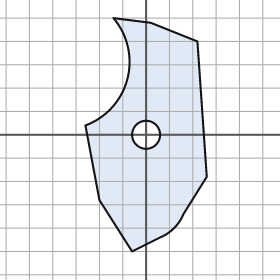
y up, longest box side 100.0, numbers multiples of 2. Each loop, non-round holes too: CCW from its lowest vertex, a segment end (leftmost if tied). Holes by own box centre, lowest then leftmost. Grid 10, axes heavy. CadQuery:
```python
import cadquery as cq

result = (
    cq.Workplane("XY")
    .moveTo(-6.0, -50.0)
    .lineTo(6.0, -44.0)
    .threePointArc((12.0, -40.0), (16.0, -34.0))
    .lineTo(26.0, -18.0)
    .lineTo(22.0, 40.0)
    .lineTo(2.0, 48.0)
    .lineTo(-14.0, 50.0)
    .threePointArc((-8.0, 24.0), (-26.0, 4.0))
    .lineTo(-20.0, -28.0)
    .close()
    .moveTo(0.0, 0.0)
    .circle(6.0)
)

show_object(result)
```